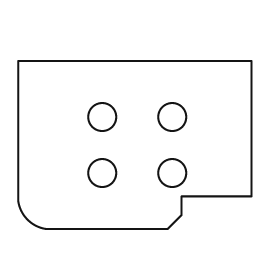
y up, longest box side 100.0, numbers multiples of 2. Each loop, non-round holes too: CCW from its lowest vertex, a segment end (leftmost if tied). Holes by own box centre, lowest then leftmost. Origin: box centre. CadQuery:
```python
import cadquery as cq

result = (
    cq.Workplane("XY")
    .moveTo(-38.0, -36.0)
    .lineTo(14.0, -36.0)
    .lineTo(20.0, -30.0)
    .lineTo(20.0, -22.0)
    .lineTo(50.0, -22.0)
    .lineTo(50.0, 36.0)
    .lineTo(-50.0, 36.0)
    .lineTo(-50.0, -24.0)
    .threePointArc((-46.0, -32.0), (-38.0, -36.0))
    .close()
    .moveTo(-14.0, -12.0)
    .circle(6.0)
    .moveTo(16.0, -12.0)
    .circle(6.0)
    .moveTo(-14.0, 12.0)
    .circle(6.0)
    .moveTo(16.0, 12.0)
    .circle(6.0)
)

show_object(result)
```